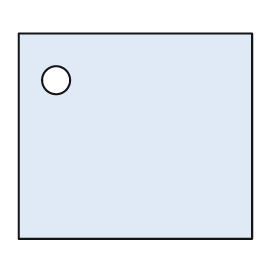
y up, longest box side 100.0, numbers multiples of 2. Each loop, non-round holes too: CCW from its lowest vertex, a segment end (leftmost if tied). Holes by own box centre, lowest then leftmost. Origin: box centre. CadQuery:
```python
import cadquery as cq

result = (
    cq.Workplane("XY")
    .moveTo(-50.0, -44.0)
    .lineTo(50.0, -44.0)
    .lineTo(50.0, 44.0)
    .lineTo(-50.0, 44.0)
    .close()
    .moveTo(-34.0, 24.0)
    .circle(6.0)
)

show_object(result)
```